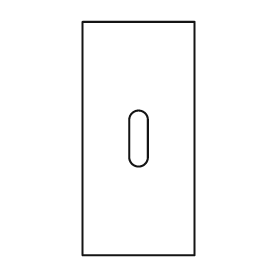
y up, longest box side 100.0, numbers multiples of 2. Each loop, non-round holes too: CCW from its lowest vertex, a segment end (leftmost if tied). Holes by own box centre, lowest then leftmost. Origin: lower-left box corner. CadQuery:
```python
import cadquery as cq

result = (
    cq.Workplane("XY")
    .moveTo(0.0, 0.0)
    .lineTo(48.0, 0.0)
    .lineTo(48.0, 100.0)
    .lineTo(0.0, 100.0)
    .close()
    .moveTo(20.0, 42.0)
    .threePointArc((24.0, 38.0), (28.0, 42.0))
    .lineTo(28.0, 58.0)
    .threePointArc((24.0, 62.0), (20.0, 58.0))
    .close()
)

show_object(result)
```